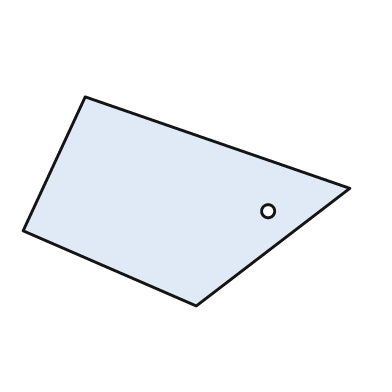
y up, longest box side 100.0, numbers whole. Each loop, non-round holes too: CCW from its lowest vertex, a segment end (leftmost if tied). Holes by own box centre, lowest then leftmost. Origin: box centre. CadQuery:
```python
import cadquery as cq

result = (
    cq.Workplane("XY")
    .moveTo(3.0, -32.0)
    .lineTo(50.0, 4.0)
    .lineTo(-31.0, 32.0)
    .lineTo(-50.0, -9.0)
    .close()
    .moveTo(25.0, -3.0)
    .circle(2.0)
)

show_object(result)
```